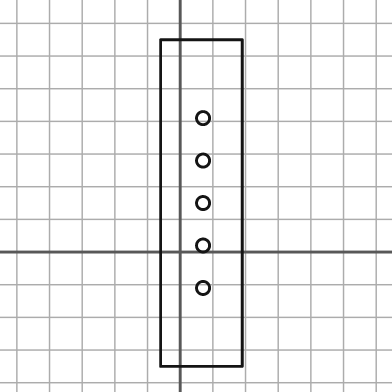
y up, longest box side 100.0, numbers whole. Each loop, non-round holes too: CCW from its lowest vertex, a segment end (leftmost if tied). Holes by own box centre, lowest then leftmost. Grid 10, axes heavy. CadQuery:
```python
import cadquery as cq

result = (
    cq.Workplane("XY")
    .moveTo(-6.0, -35.0)
    .lineTo(19.0, -35.0)
    .lineTo(19.0, 65.0)
    .lineTo(-6.0, 65.0)
    .close()
    .moveTo(7.0, -11.0)
    .circle(2.0)
    .moveTo(7.0, 2.0)
    .circle(2.0)
    .moveTo(7.0, 15.0)
    .circle(2.0)
    .moveTo(7.0, 28.0)
    .circle(2.0)
    .moveTo(7.0, 41.0)
    .circle(2.0)
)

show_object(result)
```